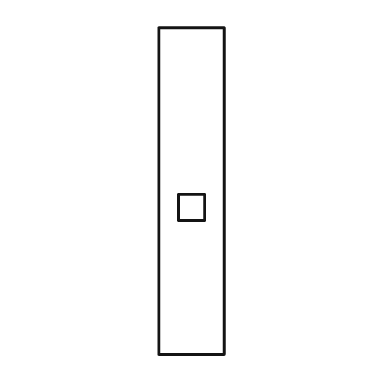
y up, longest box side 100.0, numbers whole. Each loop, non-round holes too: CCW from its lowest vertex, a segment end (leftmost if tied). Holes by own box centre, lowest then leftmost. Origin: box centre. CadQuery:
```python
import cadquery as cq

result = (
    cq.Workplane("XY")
    .moveTo(-10.0, -50.0)
    .lineTo(10.0, -50.0)
    .lineTo(10.0, 50.0)
    .lineTo(-10.0, 50.0)
    .close()
    .moveTo(-4.0, -9.0)
    .lineTo(4.0, -9.0)
    .lineTo(4.0, -1.0)
    .lineTo(-4.0, -1.0)
    .close()
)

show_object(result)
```